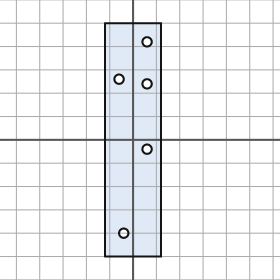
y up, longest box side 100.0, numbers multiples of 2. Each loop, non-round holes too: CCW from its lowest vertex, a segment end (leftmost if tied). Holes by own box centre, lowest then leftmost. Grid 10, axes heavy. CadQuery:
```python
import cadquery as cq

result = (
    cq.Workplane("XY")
    .moveTo(-12.0, -50.0)
    .lineTo(12.0, -50.0)
    .lineTo(12.0, 50.0)
    .lineTo(-12.0, 50.0)
    .close()
    .moveTo(-4.0, -40.0)
    .circle(2.0)
    .moveTo(6.0, -4.0)
    .circle(2.0)
    .moveTo(6.0, 24.0)
    .circle(2.0)
    .moveTo(-6.0, 26.0)
    .circle(2.0)
    .moveTo(6.0, 42.0)
    .circle(2.0)
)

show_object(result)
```